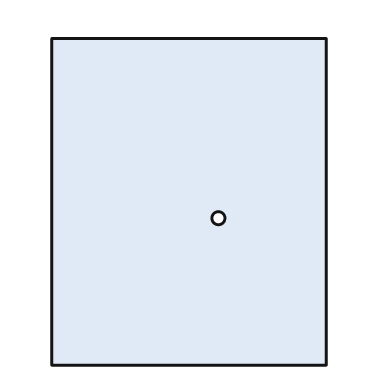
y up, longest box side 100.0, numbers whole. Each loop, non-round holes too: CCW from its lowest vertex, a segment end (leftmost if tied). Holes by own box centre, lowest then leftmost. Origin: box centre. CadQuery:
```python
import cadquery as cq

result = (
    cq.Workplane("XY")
    .moveTo(-42.0, -50.0)
    .lineTo(42.0, -50.0)
    .lineTo(42.0, 50.0)
    .lineTo(-42.0, 50.0)
    .close()
    .moveTo(9.0, -5.0)
    .circle(2.0)
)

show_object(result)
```